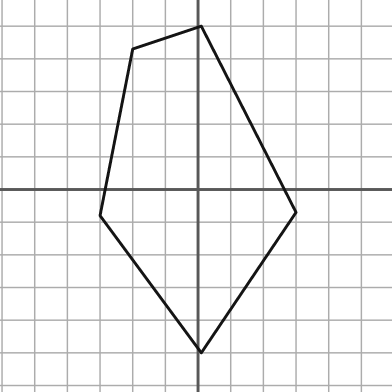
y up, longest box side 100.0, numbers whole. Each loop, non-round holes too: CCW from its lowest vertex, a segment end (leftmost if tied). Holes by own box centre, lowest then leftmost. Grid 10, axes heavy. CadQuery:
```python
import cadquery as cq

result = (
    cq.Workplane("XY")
    .moveTo(1.0, -50.0)
    .lineTo(30.0, -7.0)
    .lineTo(1.0, 50.0)
    .lineTo(-20.0, 43.0)
    .lineTo(-30.0, -8.0)
    .close()
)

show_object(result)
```